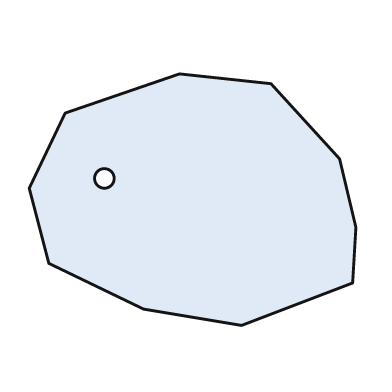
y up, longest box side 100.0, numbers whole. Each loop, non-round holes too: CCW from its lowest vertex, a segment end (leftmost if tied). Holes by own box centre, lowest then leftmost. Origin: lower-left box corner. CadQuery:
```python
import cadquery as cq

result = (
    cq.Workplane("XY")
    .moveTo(65.0, 0.0)
    .lineTo(99.0, 13.0)
    .lineTo(100.0, 30.0)
    .lineTo(95.0, 51.0)
    .lineTo(74.0, 74.0)
    .lineTo(46.0, 77.0)
    .lineTo(11.0, 65.0)
    .lineTo(0.0, 42.0)
    .lineTo(6.0, 19.0)
    .lineTo(35.0, 5.0)
    .close()
    .moveTo(23.0, 45.0)
    .circle(3.0)
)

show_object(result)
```